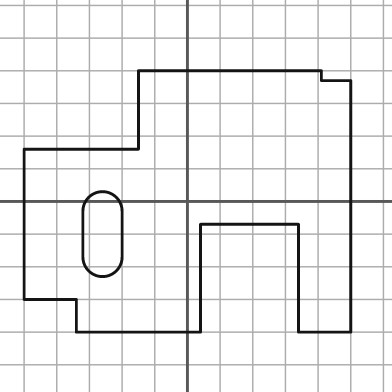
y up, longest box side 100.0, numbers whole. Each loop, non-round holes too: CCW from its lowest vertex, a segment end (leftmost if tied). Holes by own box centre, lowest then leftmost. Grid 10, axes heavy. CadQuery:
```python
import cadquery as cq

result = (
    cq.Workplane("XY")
    .moveTo(-34.0, -40.0)
    .lineTo(4.0, -40.0)
    .lineTo(4.0, -7.0)
    .lineTo(34.0, -7.0)
    .lineTo(34.0, -40.0)
    .lineTo(50.0, -40.0)
    .lineTo(50.0, 37.0)
    .lineTo(41.0, 37.0)
    .lineTo(41.0, 40.0)
    .lineTo(-15.0, 40.0)
    .lineTo(-15.0, 16.0)
    .lineTo(-50.0, 16.0)
    .lineTo(-50.0, -30.0)
    .lineTo(-34.0, -30.0)
    .close()
    .moveTo(-32.0, -17.0)
    .threePointArc((-26.0, -23.0), (-20.0, -17.0))
    .lineTo(-20.0, -3.0)
    .threePointArc((-26.0, 3.0), (-32.0, -3.0))
    .close()
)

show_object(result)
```